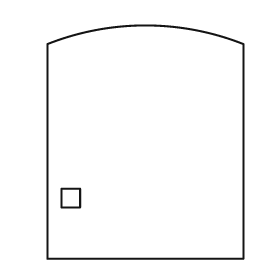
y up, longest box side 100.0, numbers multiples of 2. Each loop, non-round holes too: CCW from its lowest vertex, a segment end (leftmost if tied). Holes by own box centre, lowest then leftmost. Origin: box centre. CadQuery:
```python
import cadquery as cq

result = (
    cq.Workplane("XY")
    .moveTo(-42.0, -50.0)
    .lineTo(42.0, -50.0)
    .lineTo(42.0, 42.0)
    .threePointArc((0.0, 50.0), (-42.0, 42.0))
    .close()
    .moveTo(-36.0, -28.0)
    .lineTo(-28.0, -28.0)
    .lineTo(-28.0, -20.0)
    .lineTo(-36.0, -20.0)
    .close()
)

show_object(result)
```